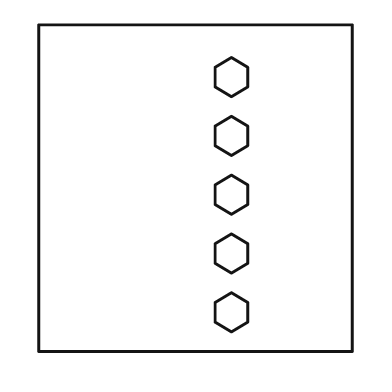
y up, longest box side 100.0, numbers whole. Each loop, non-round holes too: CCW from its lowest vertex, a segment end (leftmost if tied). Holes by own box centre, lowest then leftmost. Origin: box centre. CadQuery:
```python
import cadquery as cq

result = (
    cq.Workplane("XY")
    .moveTo(-48.0, -50.0)
    .lineTo(48.0, -50.0)
    .lineTo(48.0, 50.0)
    .lineTo(-48.0, 50.0)
    .close()
    .moveTo(11.0, -44.0)
    .lineTo(16.0, -41.0)
    .lineTo(16.0, -35.0)
    .lineTo(11.0, -32.0)
    .lineTo(6.0, -35.0)
    .lineTo(6.0, -41.0)
    .close()
    .moveTo(11.0, -26.0)
    .lineTo(16.0, -23.0)
    .lineTo(16.0, -17.0)
    .lineTo(11.0, -14.0)
    .lineTo(6.0, -17.0)
    .lineTo(6.0, -23.0)
    .close()
    .moveTo(11.0, -8.0)
    .lineTo(16.0, -5.0)
    .lineTo(16.0, 1.0)
    .lineTo(11.0, 4.0)
    .lineTo(6.0, 1.0)
    .lineTo(6.0, -5.0)
    .close()
    .moveTo(11.0, 10.0)
    .lineTo(16.0, 13.0)
    .lineTo(16.0, 19.0)
    .lineTo(11.0, 22.0)
    .lineTo(6.0, 19.0)
    .lineTo(6.0, 13.0)
    .close()
    .moveTo(11.0, 28.0)
    .lineTo(16.0, 31.0)
    .lineTo(16.0, 37.0)
    .lineTo(11.0, 40.0)
    .lineTo(6.0, 37.0)
    .lineTo(6.0, 31.0)
    .close()
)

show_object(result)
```